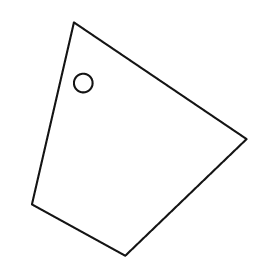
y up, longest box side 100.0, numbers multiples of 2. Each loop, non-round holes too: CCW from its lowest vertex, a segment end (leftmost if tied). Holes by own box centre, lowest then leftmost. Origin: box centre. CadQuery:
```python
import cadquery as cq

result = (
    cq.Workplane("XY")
    .moveTo(-6.0, -50.0)
    .lineTo(46.0, 0.0)
    .lineTo(-28.0, 50.0)
    .lineTo(-46.0, -28.0)
    .close()
    .moveTo(-24.0, 24.0)
    .circle(4.0)
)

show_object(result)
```